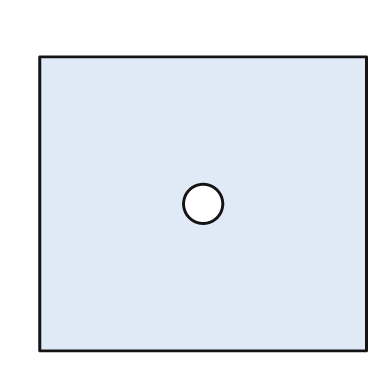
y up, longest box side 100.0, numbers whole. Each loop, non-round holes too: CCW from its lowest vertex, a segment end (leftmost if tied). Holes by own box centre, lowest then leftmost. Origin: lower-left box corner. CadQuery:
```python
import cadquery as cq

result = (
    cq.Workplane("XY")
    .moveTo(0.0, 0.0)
    .lineTo(100.0, 0.0)
    .lineTo(100.0, 90.0)
    .lineTo(0.0, 90.0)
    .close()
    .moveTo(50.0, 45.0)
    .circle(6.0)
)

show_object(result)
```